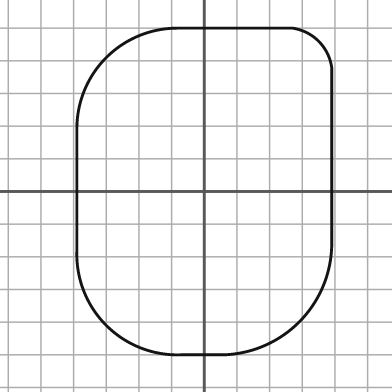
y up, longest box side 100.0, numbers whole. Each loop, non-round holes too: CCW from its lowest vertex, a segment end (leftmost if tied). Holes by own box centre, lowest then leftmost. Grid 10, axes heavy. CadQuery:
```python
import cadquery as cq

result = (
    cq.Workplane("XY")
    .moveTo(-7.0, -50.0)
    .lineTo(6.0, -50.0)
    .threePointArc((29.0, -40.0), (39.0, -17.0))
    .lineTo(39.0, 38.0)
    .threePointArc((35.0, 46.0), (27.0, 50.0))
    .lineTo(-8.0, 50.0)
    .threePointArc((-30.0, 41.0), (-39.0, 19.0))
    .lineTo(-39.0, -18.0)
    .threePointArc((-30.0, -41.0), (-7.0, -50.0))
    .close()
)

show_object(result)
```